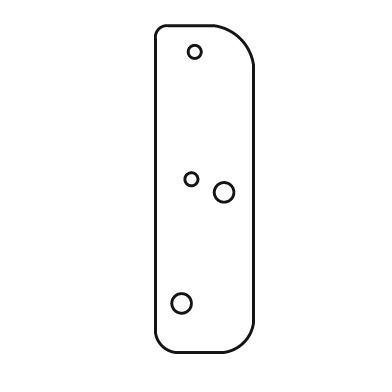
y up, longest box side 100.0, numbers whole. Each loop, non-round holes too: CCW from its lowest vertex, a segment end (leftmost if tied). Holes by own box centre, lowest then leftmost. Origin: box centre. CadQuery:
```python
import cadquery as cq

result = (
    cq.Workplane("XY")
    .moveTo(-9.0, -50.0)
    .lineTo(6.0, -50.0)
    .threePointArc((12.0, -47.0), (15.0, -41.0))
    .lineTo(15.0, 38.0)
    .threePointArc((11.0, 46.0), (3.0, 50.0))
    .lineTo(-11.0, 50.0)
    .threePointArc((-14.0, 49.0), (-15.0, 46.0))
    .lineTo(-15.0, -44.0)
    .threePointArc((-13.0, -48.0), (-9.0, -50.0))
    .close()
    .moveTo(-7.0, -35.0)
    .circle(3.0)
    .moveTo(6.0, -1.0)
    .circle(3.0)
    .moveTo(-4.0, 3.0)
    .circle(2.0)
    .moveTo(-3.0, 42.0)
    .circle(2.0)
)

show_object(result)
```